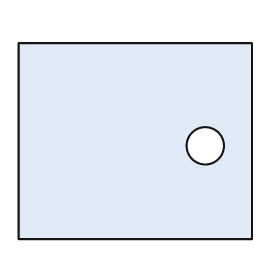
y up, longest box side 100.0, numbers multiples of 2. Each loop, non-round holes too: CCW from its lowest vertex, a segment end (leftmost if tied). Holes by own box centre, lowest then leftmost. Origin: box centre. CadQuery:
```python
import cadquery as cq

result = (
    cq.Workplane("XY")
    .moveTo(-50.0, -42.0)
    .lineTo(50.0, -42.0)
    .lineTo(50.0, 42.0)
    .lineTo(-50.0, 42.0)
    .close()
    .moveTo(30.0, -2.0)
    .circle(8.0)
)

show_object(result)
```